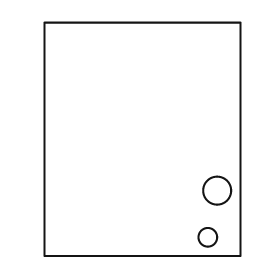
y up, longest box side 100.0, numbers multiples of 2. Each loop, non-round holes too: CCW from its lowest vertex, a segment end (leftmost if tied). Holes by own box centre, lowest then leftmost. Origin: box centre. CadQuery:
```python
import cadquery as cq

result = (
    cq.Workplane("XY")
    .moveTo(-42.0, -50.0)
    .lineTo(42.0, -50.0)
    .lineTo(42.0, 50.0)
    .lineTo(-42.0, 50.0)
    .close()
    .moveTo(28.0, -42.0)
    .circle(4.0)
    .moveTo(32.0, -22.0)
    .circle(6.0)
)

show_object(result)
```